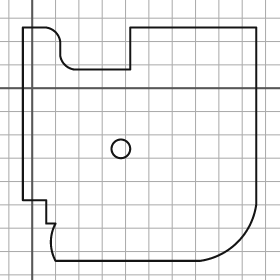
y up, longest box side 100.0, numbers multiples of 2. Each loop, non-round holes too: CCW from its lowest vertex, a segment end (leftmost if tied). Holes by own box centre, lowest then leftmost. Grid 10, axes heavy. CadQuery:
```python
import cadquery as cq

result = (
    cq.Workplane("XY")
    .moveTo(10.0, -74.0)
    .lineTo(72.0, -74.0)
    .threePointArc((88.0, -66.0), (96.0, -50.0))
    .lineTo(96.0, 26.0)
    .lineTo(42.0, 26.0)
    .lineTo(42.0, 8.0)
    .lineTo(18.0, 8.0)
    .threePointArc((14.0, 10.0), (12.0, 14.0))
    .lineTo(12.0, 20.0)
    .threePointArc((10.0, 24.0), (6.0, 26.0))
    .lineTo(-4.0, 26.0)
    .lineTo(-4.0, -48.0)
    .lineTo(6.0, -48.0)
    .lineTo(6.0, -58.0)
    .lineTo(10.0, -58.0)
    .threePointArc((8.0, -66.0), (10.0, -74.0))
    .close()
    .moveTo(38.0, -26.0)
    .circle(4.0)
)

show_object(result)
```